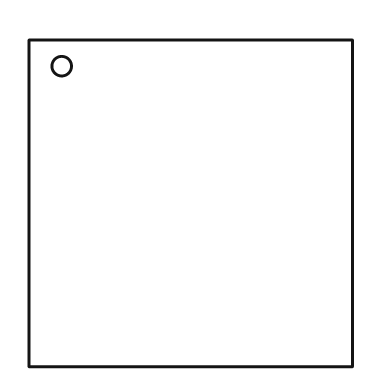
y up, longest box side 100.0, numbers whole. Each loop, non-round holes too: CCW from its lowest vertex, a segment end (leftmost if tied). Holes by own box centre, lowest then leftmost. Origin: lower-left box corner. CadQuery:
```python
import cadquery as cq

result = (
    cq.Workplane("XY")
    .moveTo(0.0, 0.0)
    .lineTo(99.0, 0.0)
    .lineTo(99.0, 100.0)
    .lineTo(0.0, 100.0)
    .close()
    .moveTo(10.0, 92.0)
    .circle(3.0)
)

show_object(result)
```